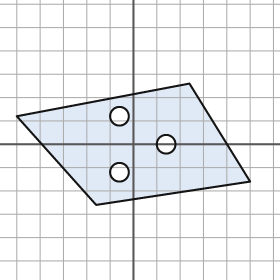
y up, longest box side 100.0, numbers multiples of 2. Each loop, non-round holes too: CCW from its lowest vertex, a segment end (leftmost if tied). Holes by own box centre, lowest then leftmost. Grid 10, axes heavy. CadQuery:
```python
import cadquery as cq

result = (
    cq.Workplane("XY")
    .moveTo(-16.0, -26.0)
    .lineTo(50.0, -16.0)
    .lineTo(24.0, 26.0)
    .lineTo(-50.0, 12.0)
    .close()
    .moveTo(-6.0, -12.0)
    .circle(4.0)
    .moveTo(14.0, 0.0)
    .circle(4.0)
    .moveTo(-6.0, 12.0)
    .circle(4.0)
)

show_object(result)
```